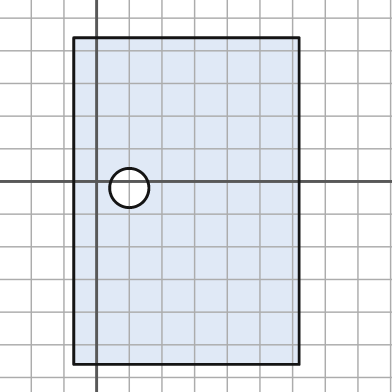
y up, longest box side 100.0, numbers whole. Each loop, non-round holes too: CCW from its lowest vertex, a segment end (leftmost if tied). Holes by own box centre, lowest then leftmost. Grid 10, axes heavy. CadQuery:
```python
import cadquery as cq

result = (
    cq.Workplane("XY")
    .moveTo(-7.0, -56.0)
    .lineTo(62.0, -56.0)
    .lineTo(62.0, 44.0)
    .lineTo(-7.0, 44.0)
    .close()
    .moveTo(10.0, -2.0)
    .circle(6.0)
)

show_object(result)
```